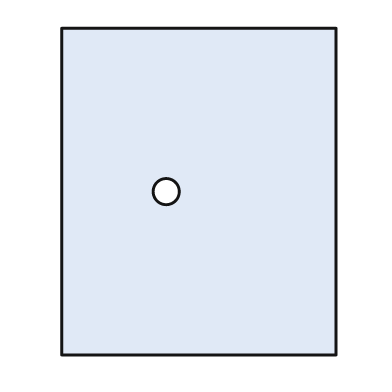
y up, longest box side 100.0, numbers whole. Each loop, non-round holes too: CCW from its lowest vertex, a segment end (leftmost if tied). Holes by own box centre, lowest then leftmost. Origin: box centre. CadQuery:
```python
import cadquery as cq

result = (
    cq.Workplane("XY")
    .moveTo(-42.0, -50.0)
    .lineTo(42.0, -50.0)
    .lineTo(42.0, 50.0)
    .lineTo(-42.0, 50.0)
    .close()
    .moveTo(-10.0, 0.0)
    .circle(4.0)
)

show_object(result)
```